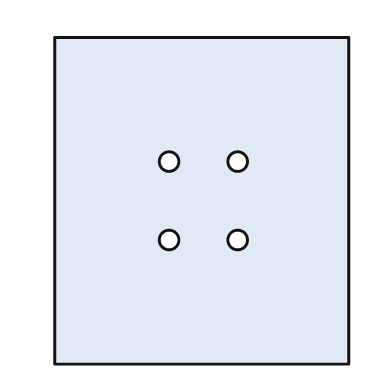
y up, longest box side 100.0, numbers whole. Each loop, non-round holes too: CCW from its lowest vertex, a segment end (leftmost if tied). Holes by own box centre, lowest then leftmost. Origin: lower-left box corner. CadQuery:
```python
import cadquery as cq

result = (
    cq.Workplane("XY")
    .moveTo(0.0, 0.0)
    .lineTo(90.0, 0.0)
    .lineTo(90.0, 100.0)
    .lineTo(0.0, 100.0)
    .close()
    .moveTo(35.0, 38.0)
    .circle(3.0)
    .moveTo(56.0, 38.0)
    .circle(3.0)
    .moveTo(35.0, 62.0)
    .circle(3.0)
    .moveTo(56.0, 62.0)
    .circle(3.0)
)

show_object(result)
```